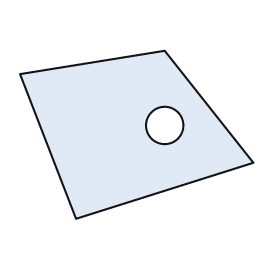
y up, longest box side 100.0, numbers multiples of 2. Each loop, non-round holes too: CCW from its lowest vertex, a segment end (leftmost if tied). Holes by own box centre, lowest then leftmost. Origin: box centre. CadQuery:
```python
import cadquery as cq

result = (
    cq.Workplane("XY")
    .moveTo(-26.0, -36.0)
    .lineTo(50.0, -12.0)
    .lineTo(12.0, 36.0)
    .lineTo(-50.0, 26.0)
    .close()
    .moveTo(12.0, 4.0)
    .circle(8.0)
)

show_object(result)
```